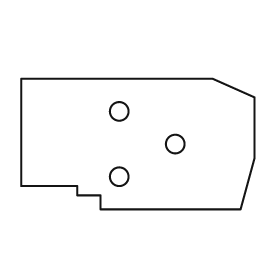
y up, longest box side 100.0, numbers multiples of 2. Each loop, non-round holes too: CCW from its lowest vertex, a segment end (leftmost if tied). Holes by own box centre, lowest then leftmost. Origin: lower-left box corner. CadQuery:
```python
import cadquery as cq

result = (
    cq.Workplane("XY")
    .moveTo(34.0, 0.0)
    .lineTo(94.0, 0.0)
    .lineTo(100.0, 22.0)
    .lineTo(100.0, 48.0)
    .lineTo(82.0, 56.0)
    .lineTo(0.0, 56.0)
    .lineTo(0.0, 10.0)
    .lineTo(24.0, 10.0)
    .lineTo(24.0, 6.0)
    .lineTo(34.0, 6.0)
    .close()
    .moveTo(42.0, 14.0)
    .circle(4.0)
    .moveTo(66.0, 28.0)
    .circle(4.0)
    .moveTo(42.0, 42.0)
    .circle(4.0)
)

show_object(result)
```